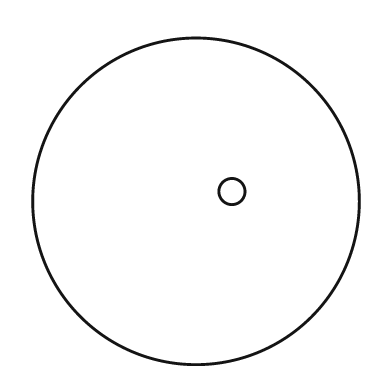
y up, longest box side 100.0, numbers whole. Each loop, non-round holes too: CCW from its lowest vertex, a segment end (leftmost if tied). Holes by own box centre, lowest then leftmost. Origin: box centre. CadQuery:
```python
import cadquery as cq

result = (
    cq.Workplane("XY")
    .moveTo(0.0, 0.0)
    .circle(50.0)
    .moveTo(11.0, 3.0)
    .circle(4.0)
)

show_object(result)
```